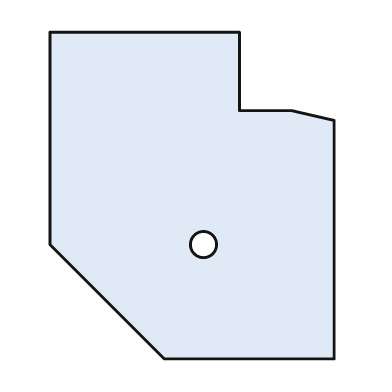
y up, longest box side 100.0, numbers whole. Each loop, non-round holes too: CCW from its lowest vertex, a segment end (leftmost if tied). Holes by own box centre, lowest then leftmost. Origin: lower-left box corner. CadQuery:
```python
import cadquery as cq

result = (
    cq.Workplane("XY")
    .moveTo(35.0, 0.0)
    .lineTo(87.0, 0.0)
    .lineTo(87.0, 73.0)
    .lineTo(74.0, 76.0)
    .lineTo(58.0, 76.0)
    .lineTo(58.0, 100.0)
    .lineTo(0.0, 100.0)
    .lineTo(0.0, 35.0)
    .close()
    .moveTo(47.0, 35.0)
    .circle(4.0)
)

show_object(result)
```